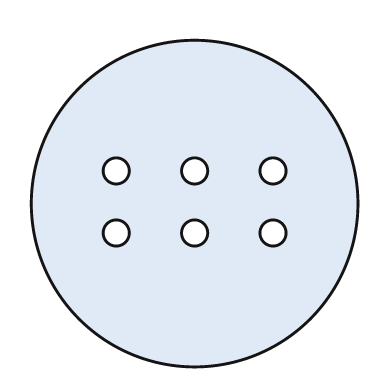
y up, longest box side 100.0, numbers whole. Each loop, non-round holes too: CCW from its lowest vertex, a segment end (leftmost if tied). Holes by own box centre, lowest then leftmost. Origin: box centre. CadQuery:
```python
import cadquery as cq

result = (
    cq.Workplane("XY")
    .moveTo(0.0, 0.0)
    .circle(50.0)
    .moveTo(-24.0, -9.0)
    .circle(4.0)
    .moveTo(0.0, -9.0)
    .circle(4.0)
    .moveTo(24.0, -9.0)
    .circle(4.0)
    .moveTo(-24.0, 10.0)
    .circle(4.0)
    .moveTo(0.0, 10.0)
    .circle(4.0)
    .moveTo(24.0, 10.0)
    .circle(4.0)
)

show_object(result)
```